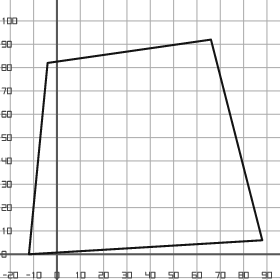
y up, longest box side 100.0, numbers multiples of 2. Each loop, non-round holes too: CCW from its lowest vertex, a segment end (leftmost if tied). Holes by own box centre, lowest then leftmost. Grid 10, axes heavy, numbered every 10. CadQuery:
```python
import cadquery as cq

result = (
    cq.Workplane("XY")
    .moveTo(-12.0, 0.0)
    .lineTo(88.0, 6.0)
    .lineTo(66.0, 92.0)
    .lineTo(-4.0, 82.0)
    .close()
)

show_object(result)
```